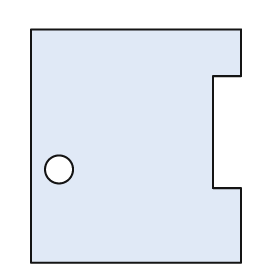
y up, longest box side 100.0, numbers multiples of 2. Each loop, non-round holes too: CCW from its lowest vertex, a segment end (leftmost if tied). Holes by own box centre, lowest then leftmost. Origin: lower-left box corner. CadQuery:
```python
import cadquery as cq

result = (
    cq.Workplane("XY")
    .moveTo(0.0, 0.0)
    .lineTo(90.0, 0.0)
    .lineTo(90.0, 32.0)
    .lineTo(78.0, 32.0)
    .lineTo(78.0, 80.0)
    .lineTo(90.0, 80.0)
    .lineTo(90.0, 100.0)
    .lineTo(0.0, 100.0)
    .close()
    .moveTo(12.0, 40.0)
    .circle(6.0)
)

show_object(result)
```